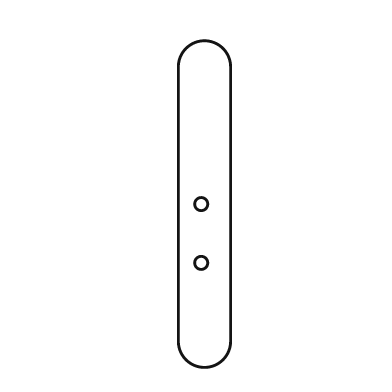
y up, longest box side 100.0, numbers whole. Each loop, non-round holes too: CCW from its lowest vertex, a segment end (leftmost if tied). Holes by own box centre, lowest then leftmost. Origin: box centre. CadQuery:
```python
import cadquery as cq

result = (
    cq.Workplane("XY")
    .moveTo(-8.0, -42.0)
    .threePointArc((0.0, -50.0), (8.0, -42.0))
    .lineTo(8.0, 42.0)
    .threePointArc((0.0, 50.0), (-8.0, 42.0))
    .close()
    .moveTo(-1.0, -18.0)
    .circle(2.0)
    .moveTo(-1.0, 0.0)
    .circle(2.0)
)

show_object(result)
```